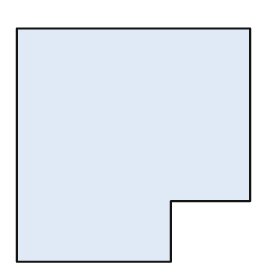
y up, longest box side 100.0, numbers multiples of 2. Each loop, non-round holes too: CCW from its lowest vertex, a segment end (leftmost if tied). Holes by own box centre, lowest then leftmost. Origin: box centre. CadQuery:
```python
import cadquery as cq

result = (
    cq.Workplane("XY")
    .moveTo(-50.0, -50.0)
    .lineTo(16.0, -50.0)
    .lineTo(16.0, -24.0)
    .lineTo(50.0, -24.0)
    .lineTo(50.0, 50.0)
    .lineTo(-50.0, 50.0)
    .close()
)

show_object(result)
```